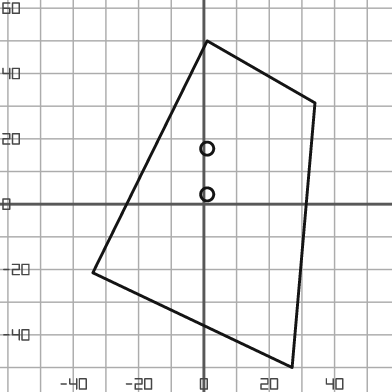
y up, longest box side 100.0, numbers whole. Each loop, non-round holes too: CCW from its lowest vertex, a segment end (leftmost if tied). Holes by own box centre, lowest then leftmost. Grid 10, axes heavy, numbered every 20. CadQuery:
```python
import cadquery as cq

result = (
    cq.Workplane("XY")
    .moveTo(27.0, -50.0)
    .lineTo(34.0, 31.0)
    .lineTo(1.0, 50.0)
    .lineTo(-34.0, -21.0)
    .close()
    .moveTo(1.0, 3.0)
    .circle(2.0)
    .moveTo(1.0, 17.0)
    .circle(2.0)
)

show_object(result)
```